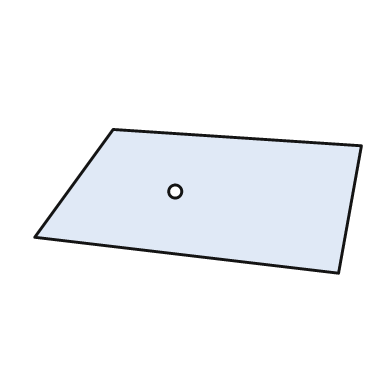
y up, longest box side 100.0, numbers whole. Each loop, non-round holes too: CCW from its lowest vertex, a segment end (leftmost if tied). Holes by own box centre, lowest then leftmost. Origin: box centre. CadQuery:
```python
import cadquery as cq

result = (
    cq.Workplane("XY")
    .moveTo(43.0, -22.0)
    .lineTo(50.0, 17.0)
    .lineTo(-26.0, 22.0)
    .lineTo(-50.0, -11.0)
    .close()
    .moveTo(-7.0, 3.0)
    .circle(2.0)
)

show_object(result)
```